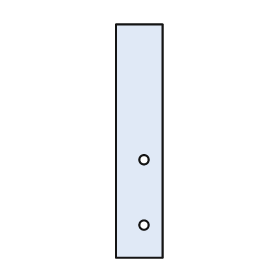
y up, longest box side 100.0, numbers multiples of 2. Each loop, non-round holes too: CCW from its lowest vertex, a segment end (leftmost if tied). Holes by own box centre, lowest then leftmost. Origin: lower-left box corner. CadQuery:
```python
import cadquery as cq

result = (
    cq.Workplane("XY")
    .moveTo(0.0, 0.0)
    .lineTo(20.0, 0.0)
    .lineTo(20.0, 100.0)
    .lineTo(0.0, 100.0)
    .close()
    .moveTo(12.0, 14.0)
    .circle(2.0)
    .moveTo(12.0, 42.0)
    .circle(2.0)
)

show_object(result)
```